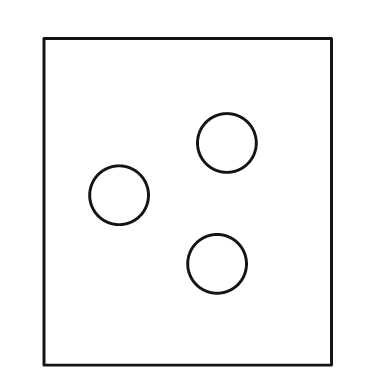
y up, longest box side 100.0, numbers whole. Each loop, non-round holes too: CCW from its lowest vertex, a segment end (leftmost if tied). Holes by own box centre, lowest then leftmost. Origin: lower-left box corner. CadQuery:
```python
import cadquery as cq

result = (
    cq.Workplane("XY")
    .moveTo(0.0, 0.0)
    .lineTo(88.0, 0.0)
    .lineTo(88.0, 100.0)
    .lineTo(0.0, 100.0)
    .close()
    .moveTo(53.0, 31.0)
    .circle(9.0)
    .moveTo(23.0, 52.0)
    .circle(9.0)
    .moveTo(56.0, 68.0)
    .circle(9.0)
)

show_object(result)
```